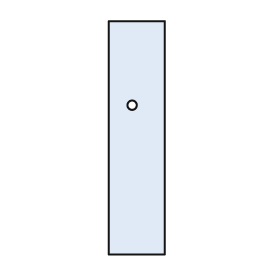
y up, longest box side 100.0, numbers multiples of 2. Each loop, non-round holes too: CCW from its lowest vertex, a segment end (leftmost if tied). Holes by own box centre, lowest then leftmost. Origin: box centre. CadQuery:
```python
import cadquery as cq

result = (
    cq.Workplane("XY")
    .moveTo(-12.0, -50.0)
    .lineTo(12.0, -50.0)
    .lineTo(12.0, 50.0)
    .lineTo(-12.0, 50.0)
    .close()
    .moveTo(-2.0, 14.0)
    .circle(2.0)
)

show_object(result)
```